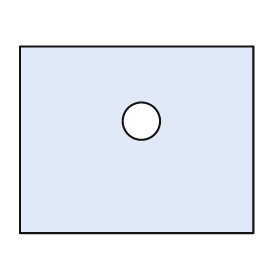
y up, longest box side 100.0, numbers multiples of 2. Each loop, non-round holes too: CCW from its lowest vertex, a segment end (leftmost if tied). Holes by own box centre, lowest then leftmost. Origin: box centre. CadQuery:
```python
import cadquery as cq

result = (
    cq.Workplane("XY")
    .moveTo(-50.0, -40.0)
    .lineTo(50.0, -40.0)
    .lineTo(50.0, 40.0)
    .lineTo(-50.0, 40.0)
    .close()
    .moveTo(2.0, 8.0)
    .circle(8.0)
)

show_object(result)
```